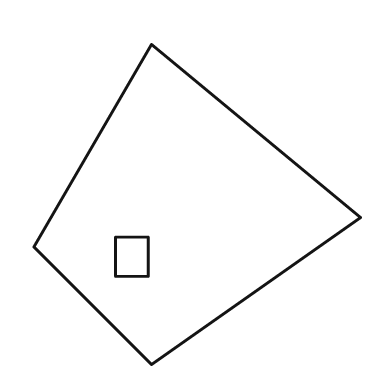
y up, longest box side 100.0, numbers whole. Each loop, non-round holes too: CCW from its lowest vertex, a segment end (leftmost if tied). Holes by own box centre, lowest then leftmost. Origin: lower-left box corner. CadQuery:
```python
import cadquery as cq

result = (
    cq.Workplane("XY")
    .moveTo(36.0, 0.0)
    .lineTo(100.0, 45.0)
    .lineTo(36.0, 98.0)
    .lineTo(0.0, 36.0)
    .close()
    .moveTo(25.0, 27.0)
    .lineTo(35.0, 27.0)
    .lineTo(35.0, 39.0)
    .lineTo(25.0, 39.0)
    .close()
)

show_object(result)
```